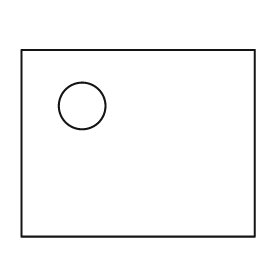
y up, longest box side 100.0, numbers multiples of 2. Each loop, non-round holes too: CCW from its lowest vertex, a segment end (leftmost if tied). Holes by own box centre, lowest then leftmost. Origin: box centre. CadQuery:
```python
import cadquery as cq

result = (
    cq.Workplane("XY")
    .moveTo(-50.0, -40.0)
    .lineTo(50.0, -40.0)
    .lineTo(50.0, 40.0)
    .lineTo(-50.0, 40.0)
    .close()
    .moveTo(-24.0, 16.0)
    .circle(10.0)
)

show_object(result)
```